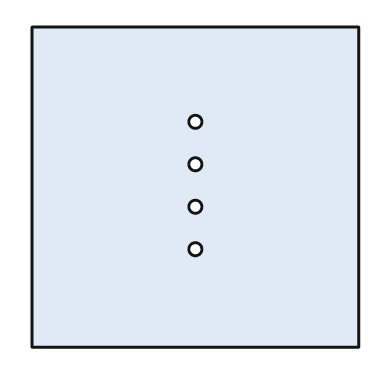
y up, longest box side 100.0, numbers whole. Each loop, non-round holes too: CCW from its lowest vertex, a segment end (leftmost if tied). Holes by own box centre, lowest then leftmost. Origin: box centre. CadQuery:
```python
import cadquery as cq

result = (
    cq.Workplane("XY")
    .moveTo(-50.0, -49.0)
    .lineTo(50.0, -49.0)
    .lineTo(50.0, 49.0)
    .lineTo(-50.0, 49.0)
    .close()
    .moveTo(0.0, -19.0)
    .circle(2.0)
    .moveTo(0.0, -6.0)
    .circle(2.0)
    .moveTo(0.0, 7.0)
    .circle(2.0)
    .moveTo(0.0, 20.0)
    .circle(2.0)
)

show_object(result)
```